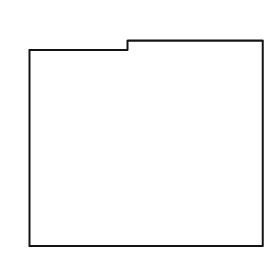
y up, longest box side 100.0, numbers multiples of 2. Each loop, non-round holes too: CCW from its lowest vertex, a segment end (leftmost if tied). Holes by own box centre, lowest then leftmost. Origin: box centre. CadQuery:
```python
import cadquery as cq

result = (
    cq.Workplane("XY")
    .moveTo(-50.0, -44.0)
    .lineTo(50.0, -44.0)
    .lineTo(50.0, 44.0)
    .lineTo(-8.0, 44.0)
    .lineTo(-8.0, 40.0)
    .lineTo(-50.0, 40.0)
    .close()
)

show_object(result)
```